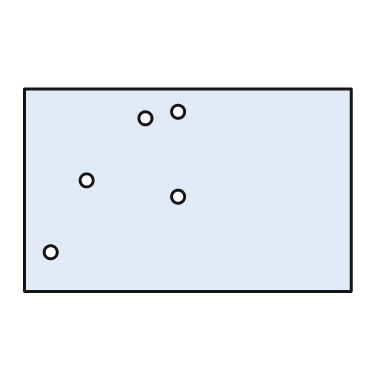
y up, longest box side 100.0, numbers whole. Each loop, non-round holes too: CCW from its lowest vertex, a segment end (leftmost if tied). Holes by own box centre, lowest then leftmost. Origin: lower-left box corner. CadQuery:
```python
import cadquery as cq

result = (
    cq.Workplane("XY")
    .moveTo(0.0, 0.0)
    .lineTo(100.0, 0.0)
    .lineTo(100.0, 62.0)
    .lineTo(0.0, 62.0)
    .close()
    .moveTo(8.0, 12.0)
    .circle(2.0)
    .moveTo(47.0, 29.0)
    .circle(2.0)
    .moveTo(19.0, 34.0)
    .circle(2.0)
    .moveTo(37.0, 53.0)
    .circle(2.0)
    .moveTo(47.0, 55.0)
    .circle(2.0)
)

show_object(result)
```